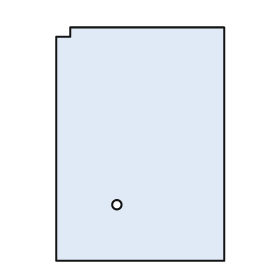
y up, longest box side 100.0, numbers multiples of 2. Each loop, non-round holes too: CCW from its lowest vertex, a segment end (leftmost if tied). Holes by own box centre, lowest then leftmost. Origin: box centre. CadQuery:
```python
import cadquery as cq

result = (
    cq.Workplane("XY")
    .moveTo(-36.0, -50.0)
    .lineTo(36.0, -50.0)
    .lineTo(36.0, 50.0)
    .lineTo(-30.0, 50.0)
    .lineTo(-30.0, 46.0)
    .lineTo(-36.0, 46.0)
    .close()
    .moveTo(-10.0, -26.0)
    .circle(2.0)
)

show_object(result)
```